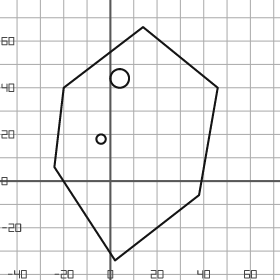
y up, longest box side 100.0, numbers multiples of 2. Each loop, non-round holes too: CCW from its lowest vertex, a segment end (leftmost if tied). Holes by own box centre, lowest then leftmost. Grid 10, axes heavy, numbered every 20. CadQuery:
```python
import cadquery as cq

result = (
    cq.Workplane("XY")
    .moveTo(2.0, -34.0)
    .lineTo(38.0, -6.0)
    .lineTo(46.0, 40.0)
    .lineTo(14.0, 66.0)
    .lineTo(-20.0, 40.0)
    .lineTo(-24.0, 6.0)
    .close()
    .moveTo(-4.0, 18.0)
    .circle(2.0)
    .moveTo(4.0, 44.0)
    .circle(4.0)
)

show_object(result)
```